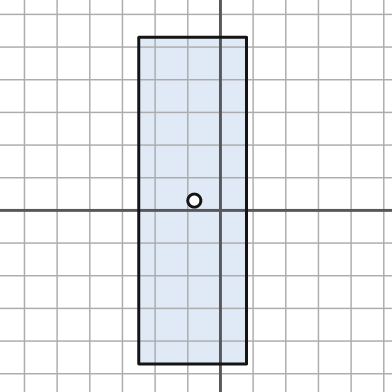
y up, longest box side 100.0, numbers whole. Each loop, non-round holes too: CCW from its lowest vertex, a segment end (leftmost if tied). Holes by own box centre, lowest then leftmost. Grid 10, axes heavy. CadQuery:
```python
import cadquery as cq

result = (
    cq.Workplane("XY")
    .moveTo(-25.0, -47.0)
    .lineTo(8.0, -47.0)
    .lineTo(8.0, 53.0)
    .lineTo(-25.0, 53.0)
    .close()
    .moveTo(-8.0, 3.0)
    .circle(2.0)
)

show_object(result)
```